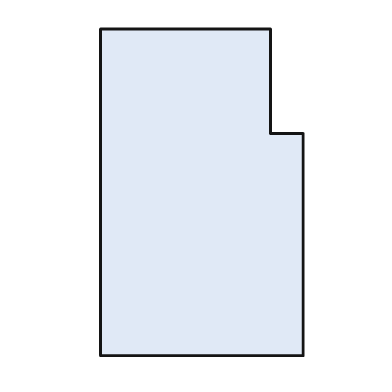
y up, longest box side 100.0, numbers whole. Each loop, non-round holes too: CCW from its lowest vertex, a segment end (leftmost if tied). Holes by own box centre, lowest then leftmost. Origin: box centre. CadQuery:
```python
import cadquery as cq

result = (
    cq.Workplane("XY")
    .moveTo(-31.0, -50.0)
    .lineTo(31.0, -50.0)
    .lineTo(31.0, 18.0)
    .lineTo(21.0, 18.0)
    .lineTo(21.0, 50.0)
    .lineTo(-31.0, 50.0)
    .close()
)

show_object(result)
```